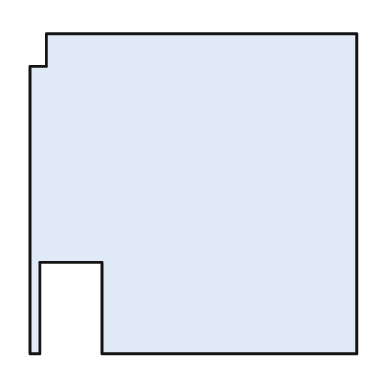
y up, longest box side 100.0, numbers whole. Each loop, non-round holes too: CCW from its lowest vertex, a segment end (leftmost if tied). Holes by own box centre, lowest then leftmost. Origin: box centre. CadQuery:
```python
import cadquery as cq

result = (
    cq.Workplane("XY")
    .moveTo(-50.0, -49.0)
    .lineTo(-47.0, -49.0)
    .lineTo(-47.0, -21.0)
    .lineTo(-28.0, -21.0)
    .lineTo(-28.0, -49.0)
    .lineTo(50.0, -49.0)
    .lineTo(50.0, 49.0)
    .lineTo(-45.0, 49.0)
    .lineTo(-45.0, 39.0)
    .lineTo(-50.0, 39.0)
    .close()
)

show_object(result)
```